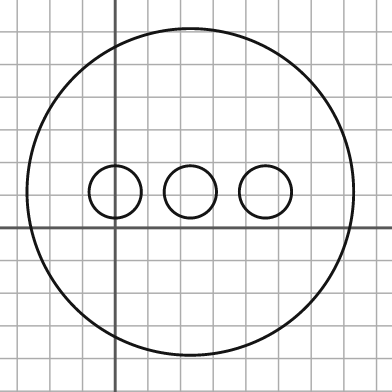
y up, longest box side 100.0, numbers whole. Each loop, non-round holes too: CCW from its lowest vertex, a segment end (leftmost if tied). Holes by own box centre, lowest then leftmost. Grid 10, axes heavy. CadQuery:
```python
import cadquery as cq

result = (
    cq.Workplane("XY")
    .moveTo(23.0, 11.0)
    .circle(50.0)
    .moveTo(0.0, 11.0)
    .circle(8.0)
    .moveTo(23.0, 11.0)
    .circle(8.0)
    .moveTo(46.0, 11.0)
    .circle(8.0)
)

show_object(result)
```